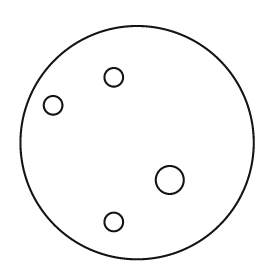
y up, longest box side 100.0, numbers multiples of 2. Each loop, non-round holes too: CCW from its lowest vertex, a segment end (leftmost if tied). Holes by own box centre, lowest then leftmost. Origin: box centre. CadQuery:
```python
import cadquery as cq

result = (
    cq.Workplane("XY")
    .moveTo(0.0, 0.0)
    .circle(50.0)
    .moveTo(-10.0, -34.0)
    .circle(4.0)
    .moveTo(14.0, -16.0)
    .circle(6.0)
    .moveTo(-36.0, 16.0)
    .circle(4.0)
    .moveTo(-10.0, 28.0)
    .circle(4.0)
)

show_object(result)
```